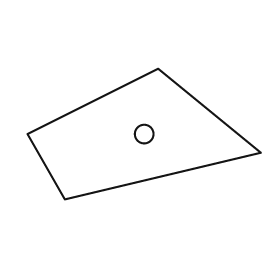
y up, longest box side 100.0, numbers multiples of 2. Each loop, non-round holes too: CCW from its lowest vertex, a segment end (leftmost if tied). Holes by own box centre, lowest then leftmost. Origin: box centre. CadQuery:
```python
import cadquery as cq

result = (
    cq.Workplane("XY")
    .moveTo(-34.0, -28.0)
    .lineTo(50.0, -8.0)
    .lineTo(6.0, 28.0)
    .lineTo(-50.0, 0.0)
    .close()
    .moveTo(0.0, 0.0)
    .circle(4.0)
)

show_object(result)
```